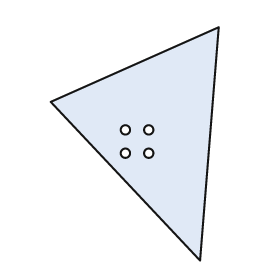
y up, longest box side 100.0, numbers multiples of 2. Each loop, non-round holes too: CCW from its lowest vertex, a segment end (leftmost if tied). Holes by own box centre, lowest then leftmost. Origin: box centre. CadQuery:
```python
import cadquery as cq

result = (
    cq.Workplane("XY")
    .moveTo(28.0, -50.0)
    .lineTo(36.0, 50.0)
    .lineTo(-36.0, 18.0)
    .close()
    .moveTo(-4.0, -4.0)
    .circle(2.0)
    .moveTo(6.0, -4.0)
    .circle(2.0)
    .moveTo(-4.0, 6.0)
    .circle(2.0)
    .moveTo(6.0, 6.0)
    .circle(2.0)
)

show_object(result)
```